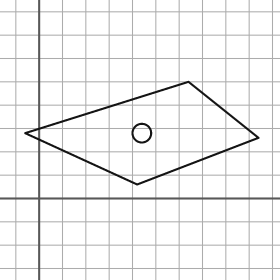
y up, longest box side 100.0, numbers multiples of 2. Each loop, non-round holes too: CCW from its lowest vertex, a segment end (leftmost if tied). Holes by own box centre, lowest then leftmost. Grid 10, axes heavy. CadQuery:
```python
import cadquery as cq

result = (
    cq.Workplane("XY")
    .moveTo(42.0, 6.0)
    .lineTo(94.0, 26.0)
    .lineTo(64.0, 50.0)
    .lineTo(-6.0, 28.0)
    .close()
    .moveTo(44.0, 28.0)
    .circle(4.0)
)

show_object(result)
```